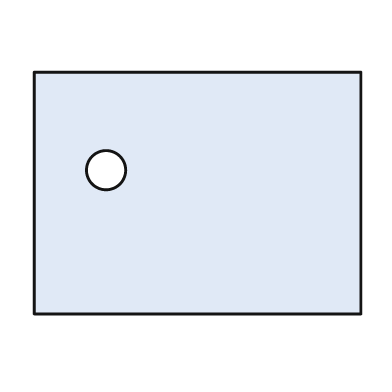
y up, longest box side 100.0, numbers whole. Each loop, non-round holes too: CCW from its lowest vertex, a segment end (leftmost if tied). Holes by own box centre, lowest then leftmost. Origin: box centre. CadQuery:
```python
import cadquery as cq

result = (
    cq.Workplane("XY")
    .moveTo(-50.0, -37.0)
    .lineTo(50.0, -37.0)
    .lineTo(50.0, 37.0)
    .lineTo(-50.0, 37.0)
    .close()
    .moveTo(-28.0, 7.0)
    .circle(6.0)
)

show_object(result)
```